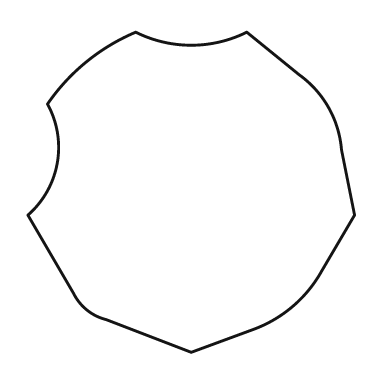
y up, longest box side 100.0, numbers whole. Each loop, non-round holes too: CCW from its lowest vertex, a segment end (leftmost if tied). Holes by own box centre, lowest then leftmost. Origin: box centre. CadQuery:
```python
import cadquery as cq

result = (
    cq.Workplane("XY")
    .moveTo(0.0, -49.0)
    .lineTo(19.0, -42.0)
    .threePointArc((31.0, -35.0), (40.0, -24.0))
    .lineTo(50.0, -7.0)
    .lineTo(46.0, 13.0)
    .threePointArc((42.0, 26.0), (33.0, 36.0))
    .lineTo(17.0, 49.0)
    .threePointArc((0.0, 45.0), (-17.0, 49.0))
    .threePointArc((-32.0, 40.0), (-44.0, 27.0))
    .threePointArc((-41.0, 9.0), (-50.0, -7.0))
    .lineTo(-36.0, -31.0)
    .threePointArc((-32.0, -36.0), (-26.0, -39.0))
    .close()
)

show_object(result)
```